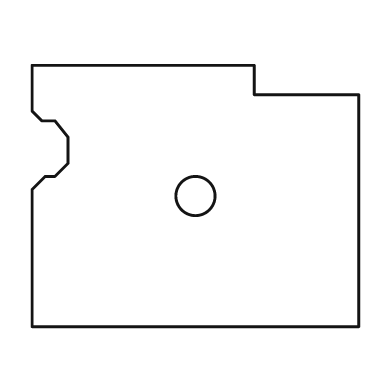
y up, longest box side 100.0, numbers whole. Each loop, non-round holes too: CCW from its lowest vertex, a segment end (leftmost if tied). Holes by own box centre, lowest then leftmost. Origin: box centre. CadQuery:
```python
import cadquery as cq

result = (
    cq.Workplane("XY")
    .moveTo(-50.0, -40.0)
    .lineTo(50.0, -40.0)
    .lineTo(50.0, 31.0)
    .lineTo(18.0, 31.0)
    .lineTo(18.0, 40.0)
    .lineTo(-50.0, 40.0)
    .lineTo(-50.0, 26.0)
    .lineTo(-47.0, 23.0)
    .lineTo(-43.0, 23.0)
    .lineTo(-39.0, 18.0)
    .lineTo(-39.0, 10.0)
    .lineTo(-43.0, 6.0)
    .lineTo(-46.0, 6.0)
    .lineTo(-50.0, 2.0)
    .close()
    .moveTo(0.0, 0.0)
    .circle(6.0)
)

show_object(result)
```